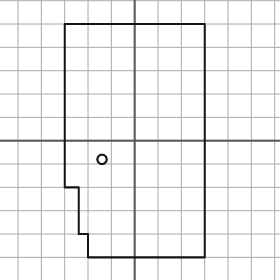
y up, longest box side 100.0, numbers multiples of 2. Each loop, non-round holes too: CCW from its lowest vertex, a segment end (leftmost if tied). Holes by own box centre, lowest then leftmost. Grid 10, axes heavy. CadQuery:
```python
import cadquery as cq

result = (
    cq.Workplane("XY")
    .moveTo(-20.0, -50.0)
    .lineTo(30.0, -50.0)
    .lineTo(30.0, 50.0)
    .lineTo(-30.0, 50.0)
    .lineTo(-30.0, -20.0)
    .lineTo(-24.0, -20.0)
    .lineTo(-24.0, -40.0)
    .lineTo(-20.0, -40.0)
    .close()
    .moveTo(-14.0, -8.0)
    .circle(2.0)
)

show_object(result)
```